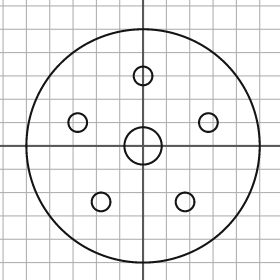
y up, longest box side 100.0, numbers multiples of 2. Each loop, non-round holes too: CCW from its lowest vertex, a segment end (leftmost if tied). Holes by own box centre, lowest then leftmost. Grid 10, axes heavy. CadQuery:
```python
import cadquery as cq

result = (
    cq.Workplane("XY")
    .moveTo(0.0, 0.0)
    .circle(50.0)
    .moveTo(-18.0, -24.0)
    .circle(4.0)
    .moveTo(18.0, -24.0)
    .circle(4.0)
    .moveTo(0.0, 0.0)
    .circle(8.0)
    .moveTo(-28.0, 10.0)
    .circle(4.0)
    .moveTo(28.0, 10.0)
    .circle(4.0)
    .moveTo(0.0, 30.0)
    .circle(4.0)
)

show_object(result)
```